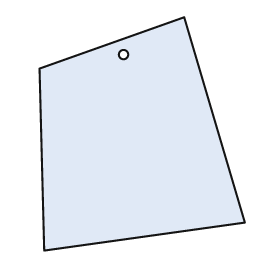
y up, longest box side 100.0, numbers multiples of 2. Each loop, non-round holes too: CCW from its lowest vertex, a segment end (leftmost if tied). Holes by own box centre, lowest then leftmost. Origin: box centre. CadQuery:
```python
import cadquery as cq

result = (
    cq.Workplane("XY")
    .moveTo(-42.0, -50.0)
    .lineTo(44.0, -38.0)
    .lineTo(18.0, 50.0)
    .lineTo(-44.0, 28.0)
    .close()
    .moveTo(-8.0, 34.0)
    .circle(2.0)
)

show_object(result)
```